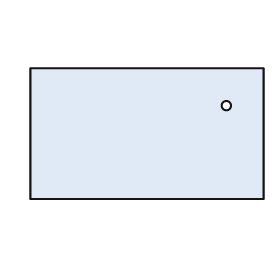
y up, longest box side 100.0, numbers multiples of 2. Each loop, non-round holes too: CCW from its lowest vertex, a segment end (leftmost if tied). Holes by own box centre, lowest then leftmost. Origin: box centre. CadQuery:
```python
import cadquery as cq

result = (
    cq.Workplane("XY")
    .moveTo(-50.0, -28.0)
    .lineTo(50.0, -28.0)
    .lineTo(50.0, 28.0)
    .lineTo(-50.0, 28.0)
    .close()
    .moveTo(34.0, 12.0)
    .circle(2.0)
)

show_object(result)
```